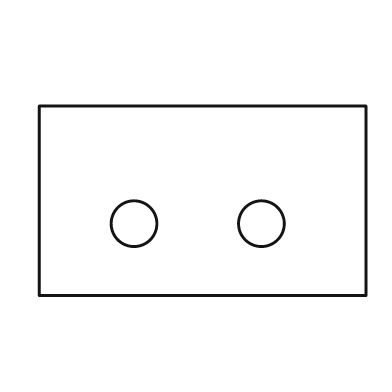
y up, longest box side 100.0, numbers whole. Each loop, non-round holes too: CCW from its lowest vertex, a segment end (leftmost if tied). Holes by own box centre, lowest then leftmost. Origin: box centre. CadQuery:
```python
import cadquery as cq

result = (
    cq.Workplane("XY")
    .moveTo(-50.0, -29.0)
    .lineTo(50.0, -29.0)
    .lineTo(50.0, 29.0)
    .lineTo(-50.0, 29.0)
    .close()
    .moveTo(-21.0, -7.0)
    .circle(7.0)
    .moveTo(18.0, -7.0)
    .circle(7.0)
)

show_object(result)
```